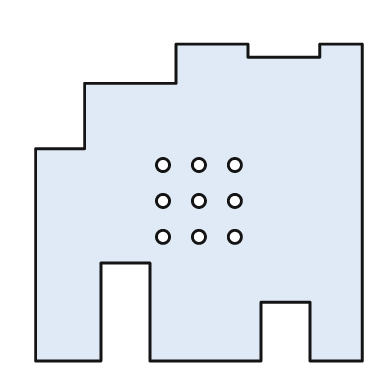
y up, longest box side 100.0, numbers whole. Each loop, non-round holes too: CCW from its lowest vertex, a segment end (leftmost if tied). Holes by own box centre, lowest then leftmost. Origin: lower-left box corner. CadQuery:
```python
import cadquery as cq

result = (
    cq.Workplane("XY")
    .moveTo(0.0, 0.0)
    .lineTo(20.0, 0.0)
    .lineTo(20.0, 30.0)
    .lineTo(35.0, 30.0)
    .lineTo(35.0, 0.0)
    .lineTo(69.0, 0.0)
    .lineTo(69.0, 18.0)
    .lineTo(84.0, 18.0)
    .lineTo(84.0, 0.0)
    .lineTo(100.0, 0.0)
    .lineTo(100.0, 97.0)
    .lineTo(87.0, 97.0)
    .lineTo(87.0, 93.0)
    .lineTo(65.0, 93.0)
    .lineTo(65.0, 97.0)
    .lineTo(43.0, 97.0)
    .lineTo(43.0, 85.0)
    .lineTo(15.0, 85.0)
    .lineTo(15.0, 65.0)
    .lineTo(0.0, 65.0)
    .close()
    .moveTo(39.0, 38.0)
    .circle(2.0)
    .moveTo(50.0, 38.0)
    .circle(2.0)
    .moveTo(61.0, 38.0)
    .circle(2.0)
    .moveTo(39.0, 49.0)
    .circle(2.0)
    .moveTo(50.0, 49.0)
    .circle(2.0)
    .moveTo(61.0, 49.0)
    .circle(2.0)
    .moveTo(39.0, 60.0)
    .circle(2.0)
    .moveTo(50.0, 60.0)
    .circle(2.0)
    .moveTo(61.0, 60.0)
    .circle(2.0)
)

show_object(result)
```